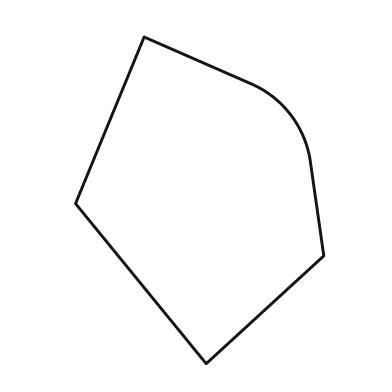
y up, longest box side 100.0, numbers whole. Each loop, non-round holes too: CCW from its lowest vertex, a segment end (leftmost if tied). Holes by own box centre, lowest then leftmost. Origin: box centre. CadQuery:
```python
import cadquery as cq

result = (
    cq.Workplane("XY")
    .moveTo(2.0, -50.0)
    .lineTo(38.0, -17.0)
    .lineTo(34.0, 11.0)
    .threePointArc((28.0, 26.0), (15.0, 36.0))
    .lineTo(-17.0, 50.0)
    .lineTo(-38.0, -1.0)
    .close()
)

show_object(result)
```